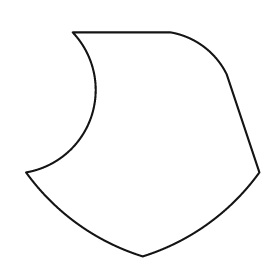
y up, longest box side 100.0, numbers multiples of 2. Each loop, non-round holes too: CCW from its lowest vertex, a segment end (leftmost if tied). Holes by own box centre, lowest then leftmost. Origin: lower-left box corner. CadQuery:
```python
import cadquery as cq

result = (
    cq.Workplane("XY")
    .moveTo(50.0, 0.0)
    .threePointArc((78.0, 14.0), (100.0, 36.0))
    .lineTo(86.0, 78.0)
    .threePointArc((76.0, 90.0), (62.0, 96.0))
    .lineTo(20.0, 96.0)
    .threePointArc((28.0, 60.0), (0.0, 36.0))
    .threePointArc((22.0, 14.0), (50.0, 0.0))
    .close()
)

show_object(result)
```